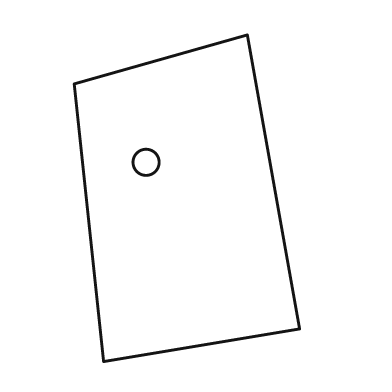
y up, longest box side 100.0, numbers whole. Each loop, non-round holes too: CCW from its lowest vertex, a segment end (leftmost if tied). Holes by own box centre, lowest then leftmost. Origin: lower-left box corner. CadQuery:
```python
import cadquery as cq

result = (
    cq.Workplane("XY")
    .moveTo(9.0, 0.0)
    .lineTo(69.0, 10.0)
    .lineTo(53.0, 100.0)
    .lineTo(0.0, 85.0)
    .close()
    .moveTo(22.0, 61.0)
    .circle(4.0)
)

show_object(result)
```